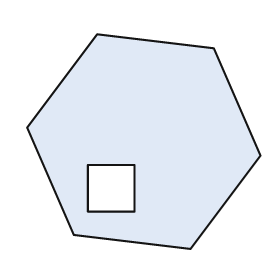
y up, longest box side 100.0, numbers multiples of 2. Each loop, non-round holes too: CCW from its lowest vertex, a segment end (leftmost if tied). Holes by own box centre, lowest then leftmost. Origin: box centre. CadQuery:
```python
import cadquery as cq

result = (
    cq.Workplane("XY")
    .moveTo(20.0, -46.0)
    .lineTo(50.0, -6.0)
    .lineTo(30.0, 40.0)
    .lineTo(-20.0, 46.0)
    .lineTo(-50.0, 6.0)
    .lineTo(-30.0, -40.0)
    .close()
    .moveTo(-24.0, -30.0)
    .lineTo(-4.0, -30.0)
    .lineTo(-4.0, -10.0)
    .lineTo(-24.0, -10.0)
    .close()
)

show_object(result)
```